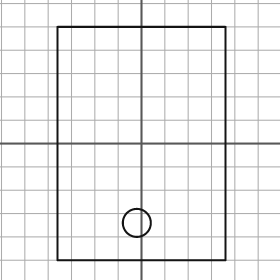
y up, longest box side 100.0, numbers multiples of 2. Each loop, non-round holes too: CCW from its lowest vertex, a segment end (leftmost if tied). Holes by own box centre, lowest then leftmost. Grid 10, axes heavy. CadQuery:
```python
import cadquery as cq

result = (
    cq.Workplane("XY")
    .moveTo(-36.0, -50.0)
    .lineTo(36.0, -50.0)
    .lineTo(36.0, 50.0)
    .lineTo(-36.0, 50.0)
    .close()
    .moveTo(-2.0, -34.0)
    .circle(6.0)
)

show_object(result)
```